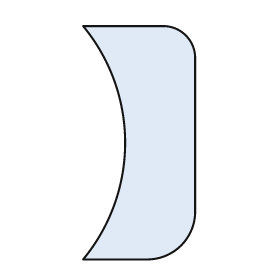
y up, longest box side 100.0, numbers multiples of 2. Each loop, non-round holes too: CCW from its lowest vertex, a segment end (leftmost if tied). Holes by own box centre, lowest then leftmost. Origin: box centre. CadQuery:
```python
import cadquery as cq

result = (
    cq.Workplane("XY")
    .moveTo(-24.0, -50.0)
    .lineTo(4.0, -50.0)
    .threePointArc((18.0, -44.0), (24.0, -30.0))
    .lineTo(24.0, 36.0)
    .threePointArc((20.0, 46.0), (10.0, 50.0))
    .lineTo(-24.0, 50.0)
    .threePointArc((-6.0, 0.0), (-24.0, -50.0))
    .close()
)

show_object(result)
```